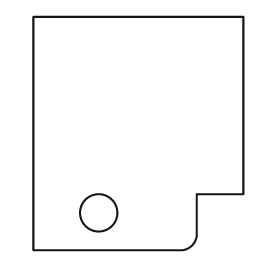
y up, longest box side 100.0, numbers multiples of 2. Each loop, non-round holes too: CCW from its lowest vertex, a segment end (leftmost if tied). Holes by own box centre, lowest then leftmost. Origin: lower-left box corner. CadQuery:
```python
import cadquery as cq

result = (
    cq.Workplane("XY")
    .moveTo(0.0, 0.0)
    .lineTo(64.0, 0.0)
    .threePointArc((68.0, 2.0), (70.0, 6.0))
    .lineTo(70.0, 24.0)
    .lineTo(90.0, 24.0)
    .lineTo(90.0, 100.0)
    .lineTo(0.0, 100.0)
    .close()
    .moveTo(28.0, 16.0)
    .circle(8.0)
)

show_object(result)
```